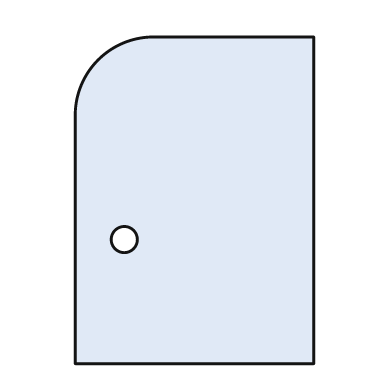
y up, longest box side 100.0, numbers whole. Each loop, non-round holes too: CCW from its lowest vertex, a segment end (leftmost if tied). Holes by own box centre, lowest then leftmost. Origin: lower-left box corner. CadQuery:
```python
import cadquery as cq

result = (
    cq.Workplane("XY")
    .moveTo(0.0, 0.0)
    .lineTo(73.0, 0.0)
    .lineTo(73.0, 100.0)
    .lineTo(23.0, 100.0)
    .threePointArc((7.0, 93.0), (0.0, 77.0))
    .close()
    .moveTo(15.0, 38.0)
    .circle(4.0)
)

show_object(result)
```